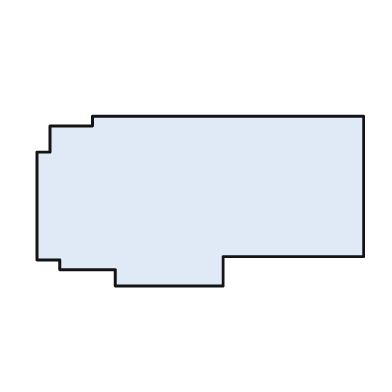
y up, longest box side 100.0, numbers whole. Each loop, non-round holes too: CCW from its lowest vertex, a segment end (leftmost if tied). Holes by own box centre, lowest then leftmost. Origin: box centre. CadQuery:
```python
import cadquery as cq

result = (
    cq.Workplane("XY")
    .moveTo(-26.0, -26.0)
    .lineTo(7.0, -26.0)
    .lineTo(7.0, -17.0)
    .lineTo(50.0, -17.0)
    .lineTo(50.0, 26.0)
    .lineTo(-33.0, 26.0)
    .lineTo(-33.0, 23.0)
    .lineTo(-46.0, 23.0)
    .lineTo(-46.0, 15.0)
    .lineTo(-50.0, 15.0)
    .lineTo(-50.0, -18.0)
    .lineTo(-43.0, -18.0)
    .lineTo(-43.0, -21.0)
    .lineTo(-26.0, -21.0)
    .close()
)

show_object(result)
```